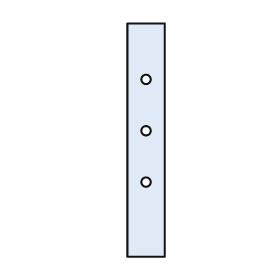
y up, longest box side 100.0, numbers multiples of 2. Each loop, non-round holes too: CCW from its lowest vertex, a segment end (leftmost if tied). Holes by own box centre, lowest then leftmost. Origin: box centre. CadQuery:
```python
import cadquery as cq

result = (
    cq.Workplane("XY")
    .moveTo(-8.0, -50.0)
    .lineTo(8.0, -50.0)
    .lineTo(8.0, 50.0)
    .lineTo(-8.0, 50.0)
    .close()
    .moveTo(0.0, -18.0)
    .circle(2.0)
    .moveTo(0.0, 4.0)
    .circle(2.0)
    .moveTo(0.0, 26.0)
    .circle(2.0)
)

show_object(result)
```